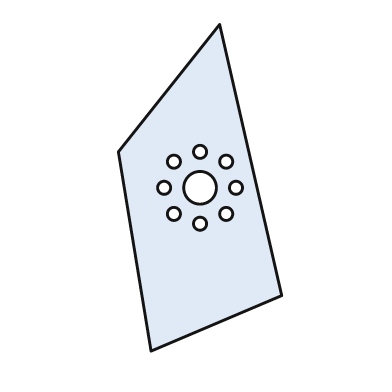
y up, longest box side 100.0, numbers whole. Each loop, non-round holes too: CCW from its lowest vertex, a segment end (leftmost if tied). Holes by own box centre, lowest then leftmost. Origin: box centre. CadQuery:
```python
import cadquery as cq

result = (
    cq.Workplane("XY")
    .moveTo(-15.0, -50.0)
    .lineTo(25.0, -33.0)
    .lineTo(6.0, 50.0)
    .lineTo(-25.0, 11.0)
    .close()
    .moveTo(0.0, -11.0)
    .circle(2.0)
    .moveTo(-8.0, -8.0)
    .circle(2.0)
    .moveTo(8.0, -8.0)
    .circle(2.0)
    .moveTo(-11.0, 0.0)
    .circle(2.0)
    .moveTo(0.0, 0.0)
    .circle(5.0)
    .moveTo(11.0, 0.0)
    .circle(2.0)
    .moveTo(-8.0, 8.0)
    .circle(2.0)
    .moveTo(8.0, 8.0)
    .circle(2.0)
    .moveTo(0.0, 11.0)
    .circle(2.0)
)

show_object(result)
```